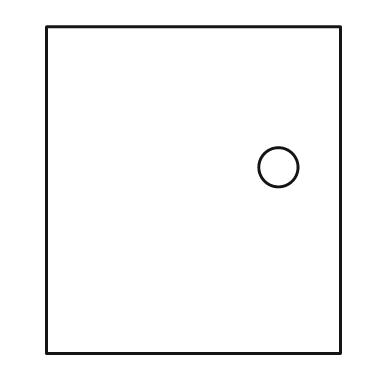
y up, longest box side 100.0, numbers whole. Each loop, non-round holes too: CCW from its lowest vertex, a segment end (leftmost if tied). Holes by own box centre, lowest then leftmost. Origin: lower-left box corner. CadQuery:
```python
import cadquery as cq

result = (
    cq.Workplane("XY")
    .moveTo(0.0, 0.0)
    .lineTo(90.0, 0.0)
    .lineTo(90.0, 100.0)
    .lineTo(0.0, 100.0)
    .close()
    .moveTo(71.0, 57.0)
    .circle(6.0)
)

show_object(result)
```